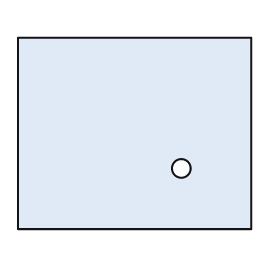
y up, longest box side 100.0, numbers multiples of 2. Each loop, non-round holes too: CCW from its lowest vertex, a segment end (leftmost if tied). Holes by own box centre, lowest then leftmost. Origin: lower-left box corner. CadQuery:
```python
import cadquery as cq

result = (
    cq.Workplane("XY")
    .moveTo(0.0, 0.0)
    .lineTo(100.0, 0.0)
    .lineTo(100.0, 82.0)
    .lineTo(0.0, 82.0)
    .close()
    .moveTo(70.0, 26.0)
    .circle(4.0)
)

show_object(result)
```